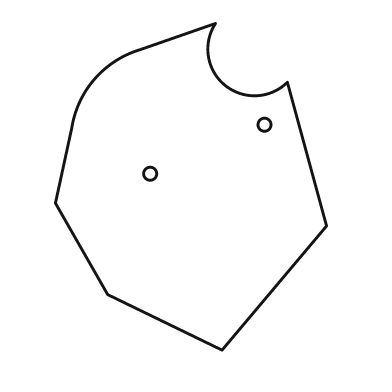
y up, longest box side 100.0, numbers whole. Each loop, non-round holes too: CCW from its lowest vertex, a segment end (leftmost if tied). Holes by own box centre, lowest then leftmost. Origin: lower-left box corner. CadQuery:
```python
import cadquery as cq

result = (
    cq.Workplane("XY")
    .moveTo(51.0, 0.0)
    .lineTo(83.0, 38.0)
    .lineTo(71.0, 82.0)
    .threePointArc((52.0, 81.0), (49.0, 100.0))
    .lineTo(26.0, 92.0)
    .threePointArc((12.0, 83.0), (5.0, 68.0))
    .lineTo(0.0, 45.0)
    .lineTo(16.0, 17.0)
    .close()
    .moveTo(29.0, 54.0)
    .circle(2.0)
    .moveTo(64.0, 69.0)
    .circle(2.0)
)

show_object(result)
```